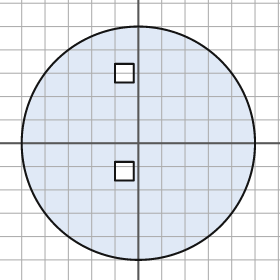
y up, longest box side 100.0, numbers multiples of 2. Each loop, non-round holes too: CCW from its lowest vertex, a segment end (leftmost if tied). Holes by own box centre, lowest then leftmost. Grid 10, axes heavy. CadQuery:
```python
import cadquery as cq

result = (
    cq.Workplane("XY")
    .moveTo(0.0, 0.0)
    .circle(50.0)
    .moveTo(-10.0, -16.0)
    .lineTo(-2.0, -16.0)
    .lineTo(-2.0, -8.0)
    .lineTo(-10.0, -8.0)
    .close()
    .moveTo(-10.0, 26.0)
    .lineTo(-2.0, 26.0)
    .lineTo(-2.0, 34.0)
    .lineTo(-10.0, 34.0)
    .close()
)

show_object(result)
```